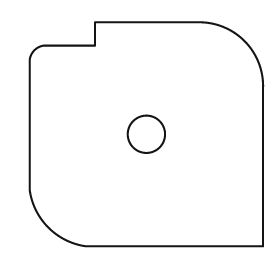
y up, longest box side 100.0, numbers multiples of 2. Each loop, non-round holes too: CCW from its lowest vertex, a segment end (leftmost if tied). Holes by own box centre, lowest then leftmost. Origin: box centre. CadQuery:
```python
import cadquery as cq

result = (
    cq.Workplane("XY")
    .moveTo(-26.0, -48.0)
    .lineTo(50.0, -48.0)
    .lineTo(50.0, 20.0)
    .threePointArc((42.0, 40.0), (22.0, 48.0))
    .lineTo(-22.0, 48.0)
    .lineTo(-22.0, 38.0)
    .lineTo(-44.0, 38.0)
    .threePointArc((-48.0, 36.0), (-50.0, 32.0))
    .lineTo(-50.0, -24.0)
    .threePointArc((-42.0, -40.0), (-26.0, -48.0))
    .close()
    .moveTo(0.0, 0.0)
    .circle(8.0)
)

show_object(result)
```